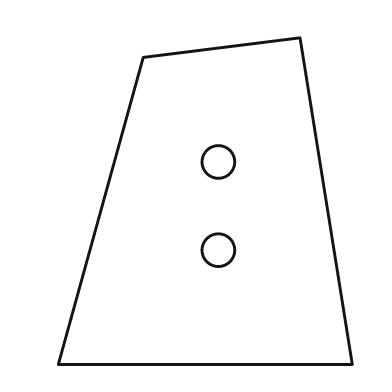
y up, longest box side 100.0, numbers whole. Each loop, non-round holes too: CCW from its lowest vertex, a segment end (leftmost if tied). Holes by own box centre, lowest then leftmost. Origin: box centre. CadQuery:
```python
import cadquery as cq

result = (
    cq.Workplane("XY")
    .moveTo(-45.0, -50.0)
    .lineTo(45.0, -50.0)
    .lineTo(29.0, 50.0)
    .lineTo(-19.0, 44.0)
    .close()
    .moveTo(4.0, -15.0)
    .circle(5.0)
    .moveTo(4.0, 12.0)
    .circle(5.0)
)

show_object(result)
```